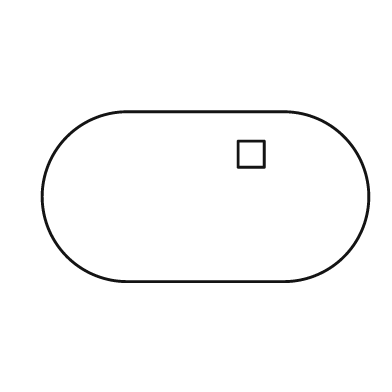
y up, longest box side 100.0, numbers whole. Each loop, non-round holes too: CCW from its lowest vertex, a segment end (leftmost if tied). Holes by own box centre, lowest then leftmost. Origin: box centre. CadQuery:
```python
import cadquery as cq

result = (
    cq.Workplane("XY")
    .moveTo(-24.0, -26.0)
    .lineTo(24.0, -26.0)
    .threePointArc((50.0, 0.0), (24.0, 26.0))
    .lineTo(-24.0, 26.0)
    .threePointArc((-50.0, 0.0), (-24.0, -26.0))
    .close()
    .moveTo(10.0, 9.0)
    .lineTo(18.0, 9.0)
    .lineTo(18.0, 17.0)
    .lineTo(10.0, 17.0)
    .close()
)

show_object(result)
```